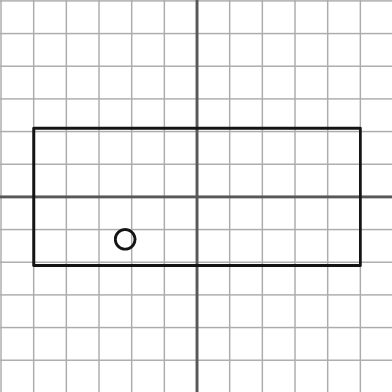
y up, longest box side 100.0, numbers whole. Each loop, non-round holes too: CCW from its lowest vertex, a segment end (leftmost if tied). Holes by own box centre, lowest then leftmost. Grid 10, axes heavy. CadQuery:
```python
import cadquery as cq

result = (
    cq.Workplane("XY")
    .moveTo(-50.0, -21.0)
    .lineTo(50.0, -21.0)
    .lineTo(50.0, 21.0)
    .lineTo(-50.0, 21.0)
    .close()
    .moveTo(-22.0, -13.0)
    .circle(3.0)
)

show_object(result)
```